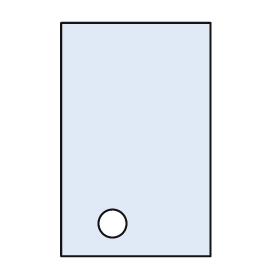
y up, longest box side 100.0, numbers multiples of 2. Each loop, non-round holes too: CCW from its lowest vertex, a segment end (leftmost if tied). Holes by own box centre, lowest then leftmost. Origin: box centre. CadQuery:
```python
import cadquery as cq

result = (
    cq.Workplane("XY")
    .moveTo(-32.0, -50.0)
    .lineTo(32.0, -50.0)
    .lineTo(32.0, 50.0)
    .lineTo(-32.0, 50.0)
    .close()
    .moveTo(-10.0, -36.0)
    .circle(6.0)
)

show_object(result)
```